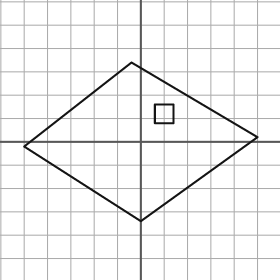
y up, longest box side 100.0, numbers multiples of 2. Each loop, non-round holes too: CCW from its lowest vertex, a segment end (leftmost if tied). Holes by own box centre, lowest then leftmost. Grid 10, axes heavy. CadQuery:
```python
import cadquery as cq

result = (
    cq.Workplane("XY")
    .moveTo(0.0, -34.0)
    .lineTo(50.0, 2.0)
    .lineTo(-4.0, 34.0)
    .lineTo(-50.0, -2.0)
    .close()
    .moveTo(6.0, 8.0)
    .lineTo(14.0, 8.0)
    .lineTo(14.0, 16.0)
    .lineTo(6.0, 16.0)
    .close()
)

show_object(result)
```